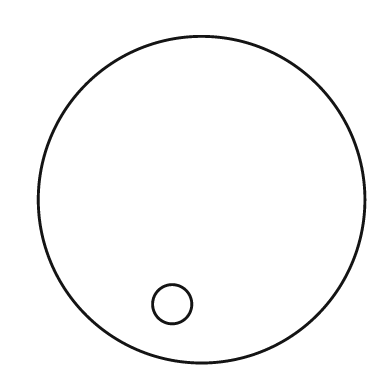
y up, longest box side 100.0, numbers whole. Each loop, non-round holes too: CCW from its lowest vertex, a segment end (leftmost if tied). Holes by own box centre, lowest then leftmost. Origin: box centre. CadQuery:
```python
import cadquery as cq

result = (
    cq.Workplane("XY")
    .moveTo(0.0, 0.0)
    .circle(50.0)
    .moveTo(-9.0, -32.0)
    .circle(6.0)
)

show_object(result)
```